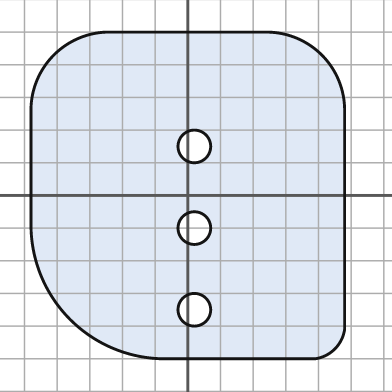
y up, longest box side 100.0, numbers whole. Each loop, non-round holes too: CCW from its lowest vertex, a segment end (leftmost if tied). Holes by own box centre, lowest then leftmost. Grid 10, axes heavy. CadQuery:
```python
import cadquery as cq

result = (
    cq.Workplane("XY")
    .moveTo(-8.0, -50.0)
    .lineTo(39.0, -50.0)
    .threePointArc((45.0, -47.0), (48.0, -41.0))
    .lineTo(48.0, 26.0)
    .threePointArc((41.0, 43.0), (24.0, 50.0))
    .lineTo(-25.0, 50.0)
    .threePointArc((-41.0, 43.0), (-48.0, 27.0))
    .lineTo(-48.0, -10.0)
    .threePointArc((-36.0, -38.0), (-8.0, -50.0))
    .close()
    .moveTo(2.0, -35.0)
    .circle(5.0)
    .moveTo(2.0, -10.0)
    .circle(5.0)
    .moveTo(2.0, 15.0)
    .circle(5.0)
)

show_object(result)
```